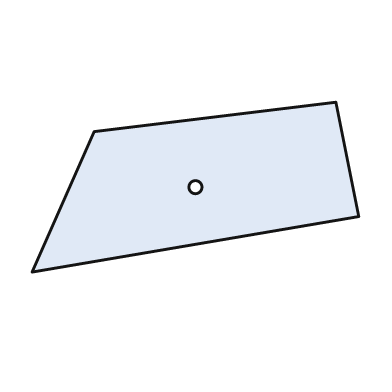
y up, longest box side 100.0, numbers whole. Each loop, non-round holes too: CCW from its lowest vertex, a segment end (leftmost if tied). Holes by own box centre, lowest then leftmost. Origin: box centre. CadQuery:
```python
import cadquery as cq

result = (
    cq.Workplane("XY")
    .moveTo(-50.0, -26.0)
    .lineTo(50.0, -9.0)
    .lineTo(43.0, 26.0)
    .lineTo(-31.0, 17.0)
    .close()
    .moveTo(0.0, 0.0)
    .circle(2.0)
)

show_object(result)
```